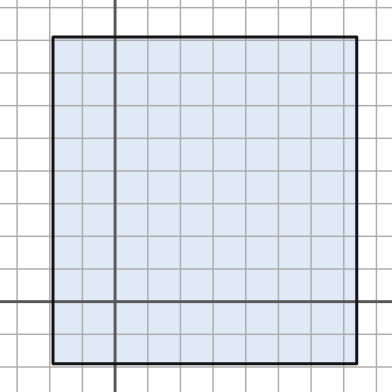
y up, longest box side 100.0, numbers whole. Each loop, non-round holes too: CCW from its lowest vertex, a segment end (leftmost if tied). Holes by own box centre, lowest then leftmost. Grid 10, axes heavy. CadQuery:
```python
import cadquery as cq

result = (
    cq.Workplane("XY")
    .moveTo(-19.0, -19.0)
    .lineTo(74.0, -19.0)
    .lineTo(74.0, 81.0)
    .lineTo(-19.0, 81.0)
    .close()
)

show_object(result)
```